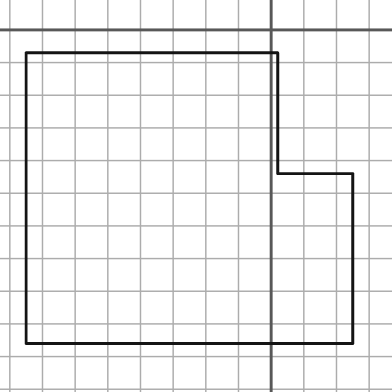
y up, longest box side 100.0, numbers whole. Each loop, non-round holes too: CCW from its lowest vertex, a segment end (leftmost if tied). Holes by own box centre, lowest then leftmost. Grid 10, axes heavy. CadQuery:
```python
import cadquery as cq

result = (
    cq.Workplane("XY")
    .moveTo(-75.0, -96.0)
    .lineTo(25.0, -96.0)
    .lineTo(25.0, -44.0)
    .lineTo(2.0, -44.0)
    .lineTo(2.0, -7.0)
    .lineTo(-75.0, -7.0)
    .close()
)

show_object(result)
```